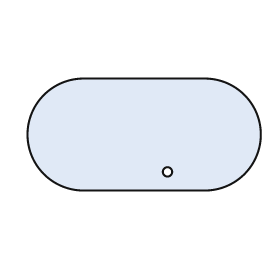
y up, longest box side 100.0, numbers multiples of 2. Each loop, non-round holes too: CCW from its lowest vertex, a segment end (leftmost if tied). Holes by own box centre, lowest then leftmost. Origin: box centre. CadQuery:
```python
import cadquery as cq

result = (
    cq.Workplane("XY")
    .moveTo(-26.0, -24.0)
    .lineTo(26.0, -24.0)
    .threePointArc((50.0, 0.0), (26.0, 24.0))
    .lineTo(-26.0, 24.0)
    .threePointArc((-50.0, 0.0), (-26.0, -24.0))
    .close()
    .moveTo(10.0, -16.0)
    .circle(2.0)
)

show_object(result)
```